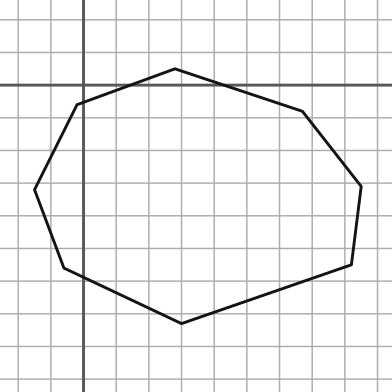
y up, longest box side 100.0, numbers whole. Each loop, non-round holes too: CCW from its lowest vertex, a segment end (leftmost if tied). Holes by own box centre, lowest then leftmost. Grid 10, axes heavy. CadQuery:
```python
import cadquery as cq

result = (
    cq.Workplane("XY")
    .moveTo(30.0, -73.0)
    .lineTo(82.0, -55.0)
    .lineTo(85.0, -31.0)
    .lineTo(67.0, -8.0)
    .lineTo(28.0, 5.0)
    .lineTo(-2.0, -6.0)
    .lineTo(-15.0, -32.0)
    .lineTo(-6.0, -56.0)
    .close()
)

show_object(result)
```